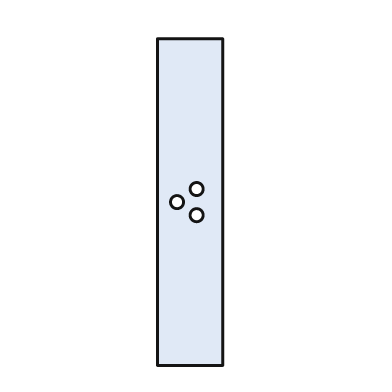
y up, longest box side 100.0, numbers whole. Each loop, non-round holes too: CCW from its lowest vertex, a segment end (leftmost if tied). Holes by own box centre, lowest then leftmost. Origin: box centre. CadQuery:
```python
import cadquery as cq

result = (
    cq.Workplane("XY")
    .moveTo(-10.0, -50.0)
    .lineTo(10.0, -50.0)
    .lineTo(10.0, 50.0)
    .lineTo(-10.0, 50.0)
    .close()
    .moveTo(2.0, -4.0)
    .circle(2.0)
    .moveTo(-4.0, 0.0)
    .circle(2.0)
    .moveTo(2.0, 4.0)
    .circle(2.0)
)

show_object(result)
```